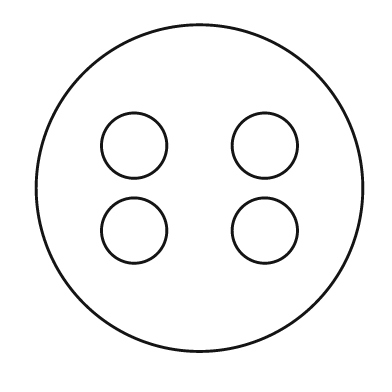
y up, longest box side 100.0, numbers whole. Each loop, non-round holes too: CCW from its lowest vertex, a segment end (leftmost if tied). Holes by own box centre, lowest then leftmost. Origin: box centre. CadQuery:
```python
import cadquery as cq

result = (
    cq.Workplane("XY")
    .moveTo(0.0, 0.0)
    .circle(50.0)
    .moveTo(-20.0, -13.0)
    .circle(10.0)
    .moveTo(20.0, -13.0)
    .circle(10.0)
    .moveTo(-20.0, 13.0)
    .circle(10.0)
    .moveTo(20.0, 13.0)
    .circle(10.0)
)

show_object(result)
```